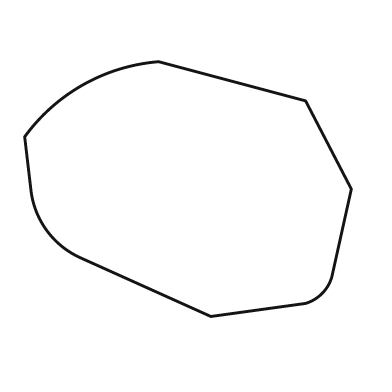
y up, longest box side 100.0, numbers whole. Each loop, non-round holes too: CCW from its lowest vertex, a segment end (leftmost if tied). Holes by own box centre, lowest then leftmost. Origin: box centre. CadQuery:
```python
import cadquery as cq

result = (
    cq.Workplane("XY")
    .moveTo(7.0, -39.0)
    .lineTo(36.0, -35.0)
    .threePointArc((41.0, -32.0), (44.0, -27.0))
    .lineTo(50.0, 0.0)
    .lineTo(36.0, 27.0)
    .lineTo(-9.0, 39.0)
    .threePointArc((-32.0, 32.0), (-50.0, 16.0))
    .lineTo(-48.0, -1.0)
    .threePointArc((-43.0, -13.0), (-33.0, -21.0))
    .close()
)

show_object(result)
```